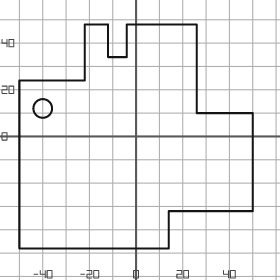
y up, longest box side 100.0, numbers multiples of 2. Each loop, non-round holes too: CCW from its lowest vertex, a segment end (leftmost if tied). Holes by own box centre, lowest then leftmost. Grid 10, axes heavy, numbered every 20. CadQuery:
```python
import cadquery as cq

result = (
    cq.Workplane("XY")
    .moveTo(-50.0, -48.0)
    .lineTo(14.0, -48.0)
    .lineTo(14.0, -32.0)
    .lineTo(50.0, -32.0)
    .lineTo(50.0, 10.0)
    .lineTo(26.0, 10.0)
    .lineTo(26.0, 48.0)
    .lineTo(-4.0, 48.0)
    .lineTo(-4.0, 34.0)
    .lineTo(-12.0, 34.0)
    .lineTo(-12.0, 48.0)
    .lineTo(-22.0, 48.0)
    .lineTo(-22.0, 24.0)
    .lineTo(-50.0, 24.0)
    .close()
    .moveTo(-40.0, 12.0)
    .circle(4.0)
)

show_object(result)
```